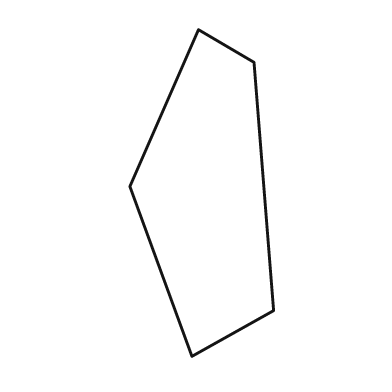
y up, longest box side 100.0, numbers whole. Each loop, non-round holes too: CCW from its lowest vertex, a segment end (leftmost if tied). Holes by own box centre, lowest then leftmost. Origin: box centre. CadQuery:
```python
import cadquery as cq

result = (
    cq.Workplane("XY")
    .moveTo(-3.0, -50.0)
    .lineTo(22.0, -36.0)
    .lineTo(16.0, 40.0)
    .lineTo(-1.0, 50.0)
    .lineTo(-22.0, 2.0)
    .close()
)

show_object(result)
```